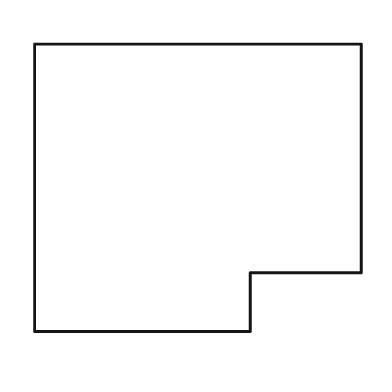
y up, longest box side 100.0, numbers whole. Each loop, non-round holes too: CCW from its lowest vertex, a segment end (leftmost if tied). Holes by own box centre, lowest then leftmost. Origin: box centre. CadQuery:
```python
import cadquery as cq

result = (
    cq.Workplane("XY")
    .moveTo(-50.0, -44.0)
    .lineTo(16.0, -44.0)
    .lineTo(16.0, -26.0)
    .lineTo(50.0, -26.0)
    .lineTo(50.0, 44.0)
    .lineTo(-50.0, 44.0)
    .close()
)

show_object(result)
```